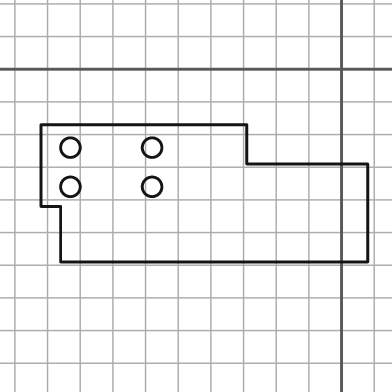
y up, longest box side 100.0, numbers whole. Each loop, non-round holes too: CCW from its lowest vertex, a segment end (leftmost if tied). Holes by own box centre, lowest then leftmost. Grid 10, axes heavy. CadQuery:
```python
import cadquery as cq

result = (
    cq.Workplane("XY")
    .moveTo(-86.0, -59.0)
    .lineTo(8.0, -59.0)
    .lineTo(8.0, -29.0)
    .lineTo(-29.0, -29.0)
    .lineTo(-29.0, -17.0)
    .lineTo(-92.0, -17.0)
    .lineTo(-92.0, -42.0)
    .lineTo(-86.0, -42.0)
    .close()
    .moveTo(-83.0, -36.0)
    .circle(3.0)
    .moveTo(-58.0, -36.0)
    .circle(3.0)
    .moveTo(-83.0, -24.0)
    .circle(3.0)
    .moveTo(-58.0, -24.0)
    .circle(3.0)
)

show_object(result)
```